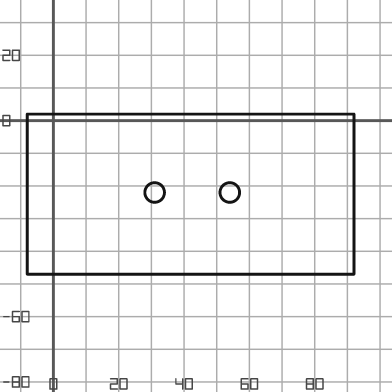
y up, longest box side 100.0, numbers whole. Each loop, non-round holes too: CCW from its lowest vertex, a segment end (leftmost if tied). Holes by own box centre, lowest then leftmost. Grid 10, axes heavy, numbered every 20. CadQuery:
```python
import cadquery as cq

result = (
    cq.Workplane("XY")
    .moveTo(-8.0, -47.0)
    .lineTo(92.0, -47.0)
    .lineTo(92.0, 2.0)
    .lineTo(-8.0, 2.0)
    .close()
    .moveTo(31.0, -22.0)
    .circle(3.0)
    .moveTo(54.0, -22.0)
    .circle(3.0)
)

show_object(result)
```